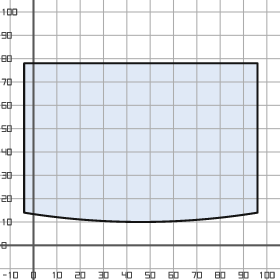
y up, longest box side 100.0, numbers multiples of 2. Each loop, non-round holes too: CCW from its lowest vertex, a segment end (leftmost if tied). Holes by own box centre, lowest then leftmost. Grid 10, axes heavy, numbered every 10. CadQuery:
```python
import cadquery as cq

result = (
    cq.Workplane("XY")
    .moveTo(-4.0, 14.0)
    .threePointArc((46.0, 10.0), (96.0, 14.0))
    .lineTo(96.0, 78.0)
    .lineTo(-4.0, 78.0)
    .close()
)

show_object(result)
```